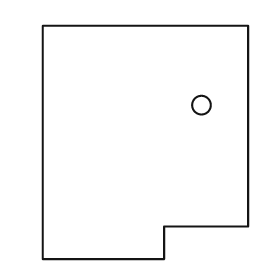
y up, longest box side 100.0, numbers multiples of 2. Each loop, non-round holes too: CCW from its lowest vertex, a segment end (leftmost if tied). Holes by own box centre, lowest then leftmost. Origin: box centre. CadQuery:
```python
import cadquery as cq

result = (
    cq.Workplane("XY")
    .moveTo(-44.0, -50.0)
    .lineTo(8.0, -50.0)
    .lineTo(8.0, -36.0)
    .lineTo(44.0, -36.0)
    .lineTo(44.0, 50.0)
    .lineTo(-44.0, 50.0)
    .close()
    .moveTo(24.0, 16.0)
    .circle(4.0)
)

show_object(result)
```